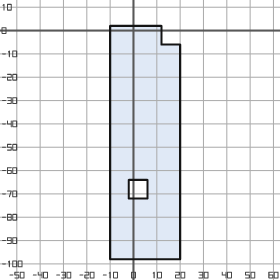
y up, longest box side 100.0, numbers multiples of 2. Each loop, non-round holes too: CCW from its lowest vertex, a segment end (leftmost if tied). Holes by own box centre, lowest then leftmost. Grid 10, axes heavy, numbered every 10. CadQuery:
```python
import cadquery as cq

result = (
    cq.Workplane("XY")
    .moveTo(-10.0, -98.0)
    .lineTo(20.0, -98.0)
    .lineTo(20.0, -6.0)
    .lineTo(12.0, -6.0)
    .lineTo(12.0, 2.0)
    .lineTo(-10.0, 2.0)
    .close()
    .moveTo(-2.0, -72.0)
    .lineTo(6.0, -72.0)
    .lineTo(6.0, -64.0)
    .lineTo(-2.0, -64.0)
    .close()
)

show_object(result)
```